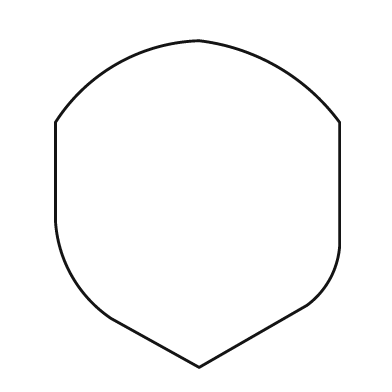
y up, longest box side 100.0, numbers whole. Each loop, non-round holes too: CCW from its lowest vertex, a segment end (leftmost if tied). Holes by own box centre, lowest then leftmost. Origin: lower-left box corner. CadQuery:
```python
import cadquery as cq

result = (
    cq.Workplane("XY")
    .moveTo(44.0, 0.0)
    .lineTo(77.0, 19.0)
    .threePointArc((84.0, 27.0), (87.0, 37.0))
    .lineTo(87.0, 75.0)
    .threePointArc((68.0, 92.0), (44.0, 100.0))
    .threePointArc((19.0, 93.0), (0.0, 75.0))
    .lineTo(0.0, 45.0)
    .threePointArc((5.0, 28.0), (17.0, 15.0))
    .close()
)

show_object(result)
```